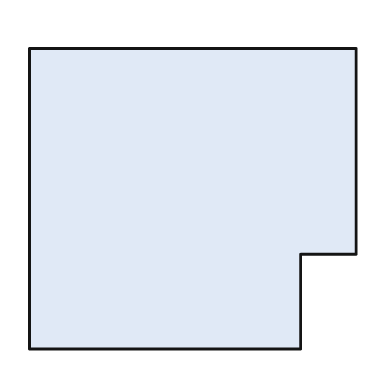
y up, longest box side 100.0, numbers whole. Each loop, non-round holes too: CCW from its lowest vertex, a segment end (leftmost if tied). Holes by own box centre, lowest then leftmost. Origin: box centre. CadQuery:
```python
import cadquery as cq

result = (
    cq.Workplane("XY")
    .moveTo(-50.0, -46.0)
    .lineTo(33.0, -46.0)
    .lineTo(33.0, -17.0)
    .lineTo(50.0, -17.0)
    .lineTo(50.0, 46.0)
    .lineTo(-50.0, 46.0)
    .close()
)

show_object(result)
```